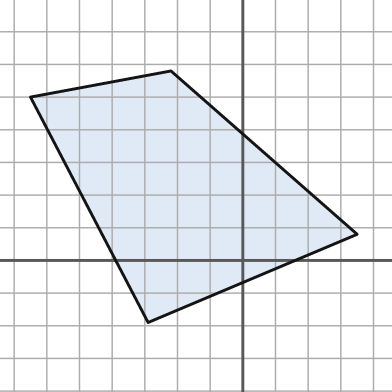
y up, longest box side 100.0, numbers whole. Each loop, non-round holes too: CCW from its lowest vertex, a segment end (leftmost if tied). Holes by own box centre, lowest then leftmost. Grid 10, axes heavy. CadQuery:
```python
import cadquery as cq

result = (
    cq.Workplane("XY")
    .moveTo(-29.0, -19.0)
    .lineTo(35.0, 8.0)
    .lineTo(-22.0, 58.0)
    .lineTo(-65.0, 50.0)
    .close()
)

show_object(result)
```